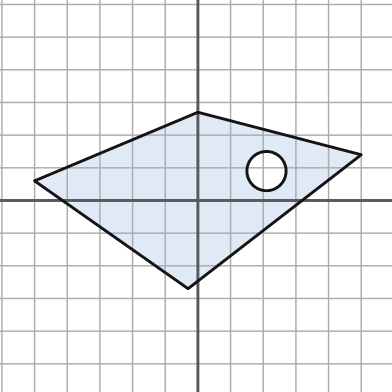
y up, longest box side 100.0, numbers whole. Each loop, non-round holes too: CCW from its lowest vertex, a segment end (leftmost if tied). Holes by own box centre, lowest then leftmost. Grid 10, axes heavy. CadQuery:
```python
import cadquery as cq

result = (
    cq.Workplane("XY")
    .moveTo(-3.0, -27.0)
    .lineTo(50.0, 14.0)
    .lineTo(0.0, 27.0)
    .lineTo(-50.0, 6.0)
    .close()
    .moveTo(21.0, 9.0)
    .circle(6.0)
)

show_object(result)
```